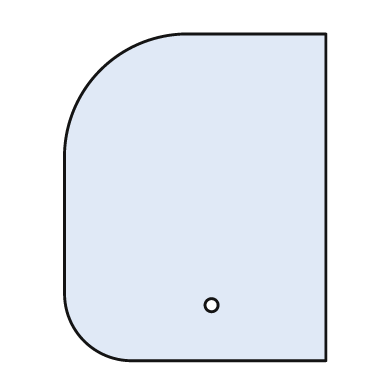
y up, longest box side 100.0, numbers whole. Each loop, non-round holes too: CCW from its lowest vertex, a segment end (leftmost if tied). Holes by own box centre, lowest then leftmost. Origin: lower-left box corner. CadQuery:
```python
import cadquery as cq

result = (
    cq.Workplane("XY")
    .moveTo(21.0, 0.0)
    .lineTo(80.0, 0.0)
    .lineTo(80.0, 100.0)
    .lineTo(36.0, 100.0)
    .threePointArc((11.0, 89.0), (0.0, 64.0))
    .lineTo(0.0, 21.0)
    .threePointArc((6.0, 6.0), (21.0, 0.0))
    .close()
    .moveTo(45.0, 17.0)
    .circle(2.0)
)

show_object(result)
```